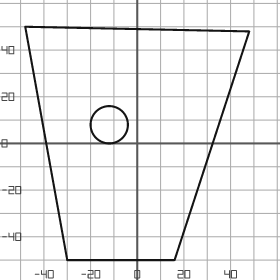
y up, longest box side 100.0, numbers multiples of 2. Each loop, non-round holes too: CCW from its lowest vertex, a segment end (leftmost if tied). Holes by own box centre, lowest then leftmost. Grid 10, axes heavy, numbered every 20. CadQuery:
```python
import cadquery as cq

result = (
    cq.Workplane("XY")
    .moveTo(-30.0, -50.0)
    .lineTo(16.0, -50.0)
    .lineTo(48.0, 48.0)
    .lineTo(-48.0, 50.0)
    .close()
    .moveTo(-12.0, 8.0)
    .circle(8.0)
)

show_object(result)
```